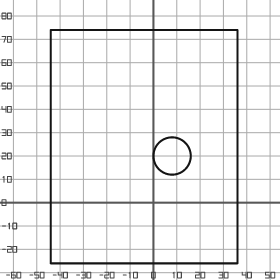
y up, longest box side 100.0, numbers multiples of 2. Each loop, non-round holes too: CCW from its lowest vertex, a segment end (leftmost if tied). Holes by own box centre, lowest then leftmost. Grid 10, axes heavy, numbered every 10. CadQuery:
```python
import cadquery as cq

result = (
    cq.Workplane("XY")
    .moveTo(-44.0, -26.0)
    .lineTo(36.0, -26.0)
    .lineTo(36.0, 74.0)
    .lineTo(-44.0, 74.0)
    .close()
    .moveTo(8.0, 20.0)
    .circle(8.0)
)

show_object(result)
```